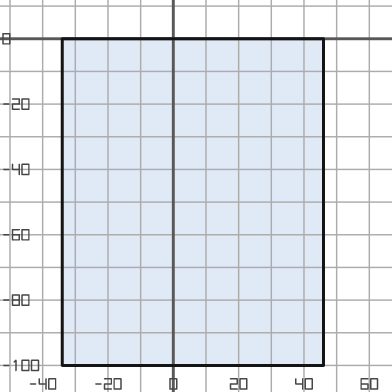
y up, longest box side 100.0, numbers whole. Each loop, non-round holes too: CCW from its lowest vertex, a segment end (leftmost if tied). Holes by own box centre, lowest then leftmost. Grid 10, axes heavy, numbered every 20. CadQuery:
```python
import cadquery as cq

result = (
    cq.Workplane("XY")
    .moveTo(-34.0, -100.0)
    .lineTo(46.0, -100.0)
    .lineTo(46.0, 0.0)
    .lineTo(-34.0, 0.0)
    .close()
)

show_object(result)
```